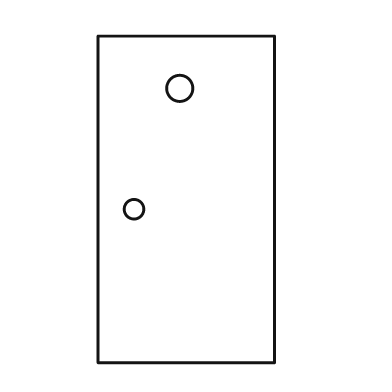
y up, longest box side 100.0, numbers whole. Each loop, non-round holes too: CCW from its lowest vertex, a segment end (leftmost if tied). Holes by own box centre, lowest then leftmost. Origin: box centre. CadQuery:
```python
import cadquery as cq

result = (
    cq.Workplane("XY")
    .moveTo(-27.0, -50.0)
    .lineTo(27.0, -50.0)
    .lineTo(27.0, 50.0)
    .lineTo(-27.0, 50.0)
    .close()
    .moveTo(-16.0, -3.0)
    .circle(3.0)
    .moveTo(-2.0, 34.0)
    .circle(4.0)
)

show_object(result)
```